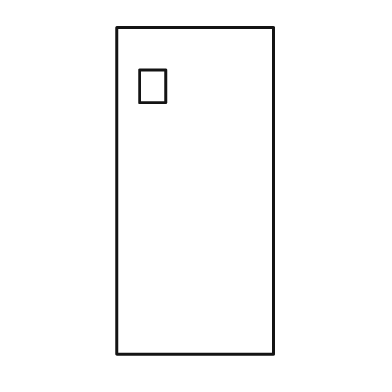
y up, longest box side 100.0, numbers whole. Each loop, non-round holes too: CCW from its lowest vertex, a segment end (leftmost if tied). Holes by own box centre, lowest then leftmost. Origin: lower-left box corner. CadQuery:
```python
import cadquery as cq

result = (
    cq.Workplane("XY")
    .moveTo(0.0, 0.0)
    .lineTo(48.0, 0.0)
    .lineTo(48.0, 100.0)
    .lineTo(0.0, 100.0)
    .close()
    .moveTo(7.0, 77.0)
    .lineTo(15.0, 77.0)
    .lineTo(15.0, 87.0)
    .lineTo(7.0, 87.0)
    .close()
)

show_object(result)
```